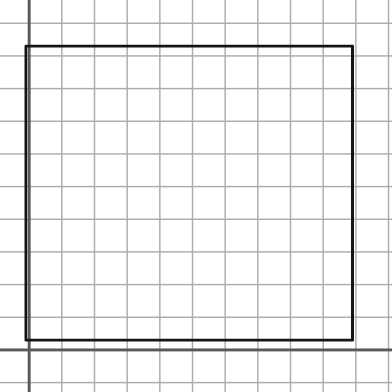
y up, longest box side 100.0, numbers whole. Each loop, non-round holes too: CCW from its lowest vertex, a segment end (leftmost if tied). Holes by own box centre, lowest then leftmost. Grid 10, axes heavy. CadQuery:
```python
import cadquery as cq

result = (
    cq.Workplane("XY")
    .moveTo(-1.0, 3.0)
    .lineTo(99.0, 3.0)
    .lineTo(99.0, 93.0)
    .lineTo(-1.0, 93.0)
    .close()
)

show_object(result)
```